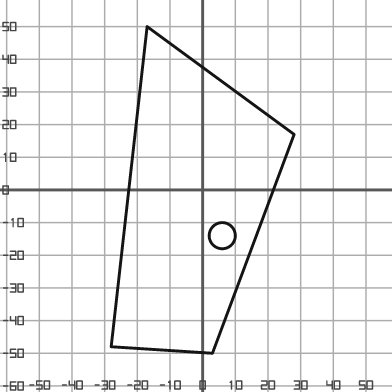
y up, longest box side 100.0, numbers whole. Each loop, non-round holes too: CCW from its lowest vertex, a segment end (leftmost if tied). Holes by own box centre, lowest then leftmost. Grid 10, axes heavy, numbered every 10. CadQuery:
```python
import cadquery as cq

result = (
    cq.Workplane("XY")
    .moveTo(3.0, -50.0)
    .lineTo(28.0, 17.0)
    .lineTo(-17.0, 50.0)
    .lineTo(-28.0, -48.0)
    .close()
    .moveTo(6.0, -14.0)
    .circle(4.0)
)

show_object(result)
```